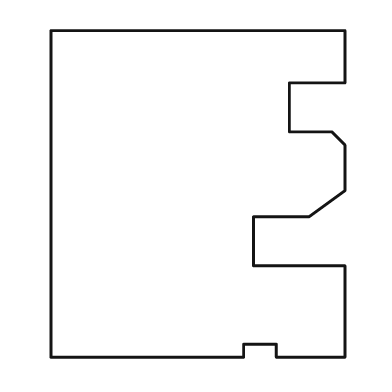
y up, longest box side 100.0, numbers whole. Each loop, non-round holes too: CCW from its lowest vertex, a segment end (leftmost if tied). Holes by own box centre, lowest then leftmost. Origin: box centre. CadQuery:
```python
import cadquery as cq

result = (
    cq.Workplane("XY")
    .moveTo(-45.0, -50.0)
    .lineTo(14.0, -50.0)
    .lineTo(14.0, -46.0)
    .lineTo(24.0, -46.0)
    .lineTo(24.0, -50.0)
    .lineTo(45.0, -50.0)
    .lineTo(45.0, -22.0)
    .lineTo(17.0, -22.0)
    .lineTo(17.0, -7.0)
    .lineTo(34.0, -7.0)
    .lineTo(45.0, 1.0)
    .lineTo(45.0, 15.0)
    .lineTo(41.0, 19.0)
    .lineTo(28.0, 19.0)
    .lineTo(28.0, 34.0)
    .lineTo(45.0, 34.0)
    .lineTo(45.0, 50.0)
    .lineTo(-45.0, 50.0)
    .close()
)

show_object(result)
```